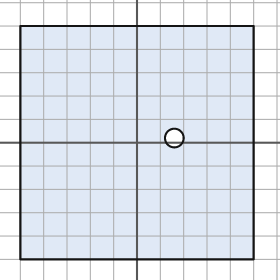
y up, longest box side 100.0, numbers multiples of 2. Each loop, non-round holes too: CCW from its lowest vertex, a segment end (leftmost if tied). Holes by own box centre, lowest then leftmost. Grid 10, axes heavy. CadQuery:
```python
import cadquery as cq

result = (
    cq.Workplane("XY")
    .moveTo(-50.0, -50.0)
    .lineTo(50.0, -50.0)
    .lineTo(50.0, 50.0)
    .lineTo(-50.0, 50.0)
    .close()
    .moveTo(16.0, 2.0)
    .circle(4.0)
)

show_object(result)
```